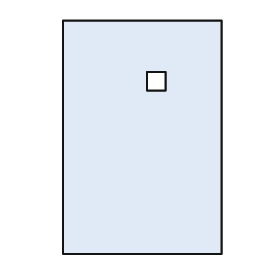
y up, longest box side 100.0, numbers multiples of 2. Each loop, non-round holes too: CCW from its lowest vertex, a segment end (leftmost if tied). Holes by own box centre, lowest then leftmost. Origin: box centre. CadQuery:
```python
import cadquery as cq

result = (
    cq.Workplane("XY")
    .moveTo(-34.0, -50.0)
    .lineTo(34.0, -50.0)
    .lineTo(34.0, 50.0)
    .lineTo(-34.0, 50.0)
    .close()
    .moveTo(2.0, 20.0)
    .lineTo(10.0, 20.0)
    .lineTo(10.0, 28.0)
    .lineTo(2.0, 28.0)
    .close()
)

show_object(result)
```